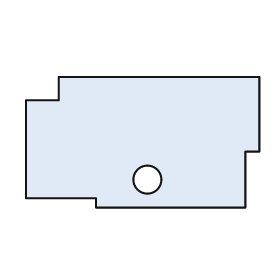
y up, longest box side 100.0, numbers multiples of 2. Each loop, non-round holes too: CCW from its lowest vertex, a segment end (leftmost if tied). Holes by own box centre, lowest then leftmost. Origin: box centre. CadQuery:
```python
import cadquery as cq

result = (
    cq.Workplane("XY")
    .moveTo(-20.0, -28.0)
    .lineTo(44.0, -28.0)
    .lineTo(44.0, -4.0)
    .lineTo(50.0, -4.0)
    .lineTo(50.0, 28.0)
    .lineTo(-36.0, 28.0)
    .lineTo(-36.0, 18.0)
    .lineTo(-50.0, 18.0)
    .lineTo(-50.0, -24.0)
    .lineTo(-20.0, -24.0)
    .close()
    .moveTo(2.0, -16.0)
    .circle(6.0)
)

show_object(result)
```